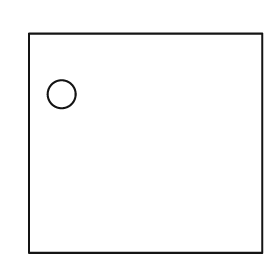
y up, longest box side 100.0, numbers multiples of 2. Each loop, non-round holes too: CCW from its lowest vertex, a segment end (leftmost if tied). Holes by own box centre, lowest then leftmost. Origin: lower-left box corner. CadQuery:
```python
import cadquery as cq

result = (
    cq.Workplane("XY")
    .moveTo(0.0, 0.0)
    .lineTo(100.0, 0.0)
    .lineTo(100.0, 94.0)
    .lineTo(0.0, 94.0)
    .close()
    .moveTo(14.0, 68.0)
    .circle(6.0)
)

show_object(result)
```